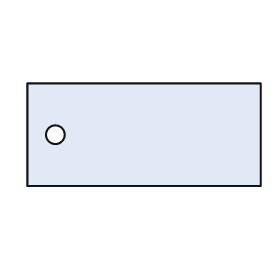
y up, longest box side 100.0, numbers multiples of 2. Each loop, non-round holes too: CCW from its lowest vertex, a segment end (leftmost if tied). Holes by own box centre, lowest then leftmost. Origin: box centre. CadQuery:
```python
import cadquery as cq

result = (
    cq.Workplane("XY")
    .moveTo(-50.0, -22.0)
    .lineTo(50.0, -22.0)
    .lineTo(50.0, 22.0)
    .lineTo(-50.0, 22.0)
    .close()
    .moveTo(-38.0, 0.0)
    .circle(4.0)
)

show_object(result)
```